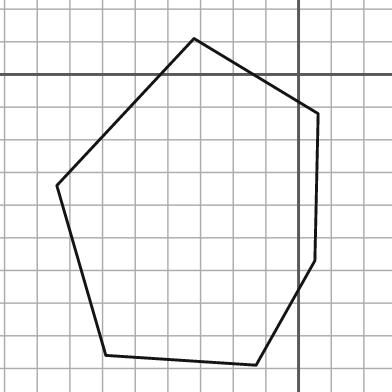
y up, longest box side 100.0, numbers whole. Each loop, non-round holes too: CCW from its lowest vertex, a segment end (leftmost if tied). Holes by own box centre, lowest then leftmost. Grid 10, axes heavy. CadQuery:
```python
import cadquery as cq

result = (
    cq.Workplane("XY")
    .moveTo(-13.0, -89.0)
    .lineTo(5.0, -57.0)
    .lineTo(6.0, -12.0)
    .lineTo(-32.0, 11.0)
    .lineTo(-74.0, -34.0)
    .lineTo(-59.0, -86.0)
    .close()
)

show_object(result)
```